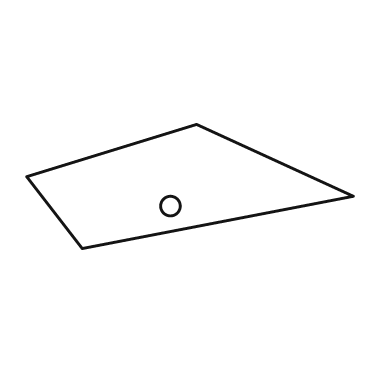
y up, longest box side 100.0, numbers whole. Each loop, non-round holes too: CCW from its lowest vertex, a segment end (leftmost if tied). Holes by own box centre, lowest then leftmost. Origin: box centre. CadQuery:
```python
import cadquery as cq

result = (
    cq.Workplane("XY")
    .moveTo(-33.0, -19.0)
    .lineTo(50.0, -3.0)
    .lineTo(2.0, 19.0)
    .lineTo(-50.0, 3.0)
    .close()
    .moveTo(-6.0, -6.0)
    .circle(3.0)
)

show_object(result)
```